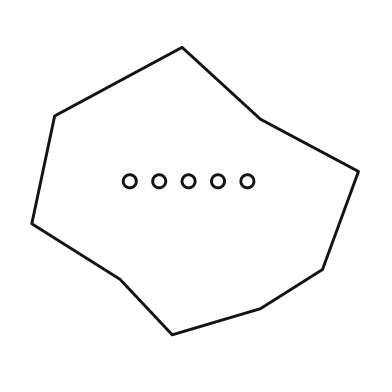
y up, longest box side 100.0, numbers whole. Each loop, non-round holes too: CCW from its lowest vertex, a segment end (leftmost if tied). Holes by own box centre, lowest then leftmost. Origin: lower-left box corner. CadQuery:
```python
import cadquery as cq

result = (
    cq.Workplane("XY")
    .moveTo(43.0, 0.0)
    .lineTo(70.0, 8.0)
    .lineTo(89.0, 20.0)
    .lineTo(100.0, 50.0)
    .lineTo(70.0, 66.0)
    .lineTo(46.0, 88.0)
    .lineTo(7.0, 67.0)
    .lineTo(0.0, 34.0)
    .lineTo(27.0, 17.0)
    .close()
    .moveTo(30.0, 47.0)
    .circle(2.0)
    .moveTo(39.0, 47.0)
    .circle(2.0)
    .moveTo(48.0, 47.0)
    .circle(2.0)
    .moveTo(57.0, 47.0)
    .circle(2.0)
    .moveTo(66.0, 47.0)
    .circle(2.0)
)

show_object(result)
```